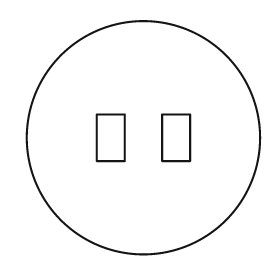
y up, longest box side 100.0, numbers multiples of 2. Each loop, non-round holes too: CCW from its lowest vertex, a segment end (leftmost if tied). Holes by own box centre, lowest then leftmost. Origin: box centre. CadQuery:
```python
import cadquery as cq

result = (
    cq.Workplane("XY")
    .moveTo(0.0, 0.0)
    .circle(50.0)
    .moveTo(-20.0, -10.0)
    .lineTo(-8.0, -10.0)
    .lineTo(-8.0, 10.0)
    .lineTo(-20.0, 10.0)
    .close()
    .moveTo(8.0, -10.0)
    .lineTo(20.0, -10.0)
    .lineTo(20.0, 10.0)
    .lineTo(8.0, 10.0)
    .close()
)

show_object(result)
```